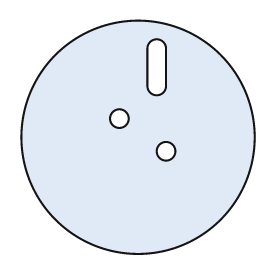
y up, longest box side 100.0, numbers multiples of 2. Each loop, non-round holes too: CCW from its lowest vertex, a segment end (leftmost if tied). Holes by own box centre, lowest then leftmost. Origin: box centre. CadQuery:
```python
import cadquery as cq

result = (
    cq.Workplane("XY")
    .moveTo(0.0, 0.0)
    .circle(50.0)
    .moveTo(12.0, -6.0)
    .circle(4.0)
    .moveTo(-8.0, 8.0)
    .circle(4.0)
    .moveTo(4.0, 22.0)
    .threePointArc((8.0, 18.0), (12.0, 22.0))
    .lineTo(12.0, 38.0)
    .threePointArc((8.0, 42.0), (4.0, 38.0))
    .close()
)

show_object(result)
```